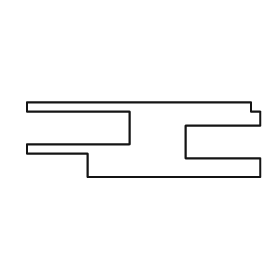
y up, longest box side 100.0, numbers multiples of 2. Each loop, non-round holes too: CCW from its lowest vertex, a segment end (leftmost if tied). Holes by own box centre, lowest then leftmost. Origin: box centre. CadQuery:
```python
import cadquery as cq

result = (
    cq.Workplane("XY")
    .moveTo(-24.0, -16.0)
    .lineTo(50.0, -16.0)
    .lineTo(50.0, -8.0)
    .lineTo(18.0, -8.0)
    .lineTo(18.0, 6.0)
    .lineTo(50.0, 6.0)
    .lineTo(50.0, 12.0)
    .lineTo(46.0, 12.0)
    .lineTo(46.0, 16.0)
    .lineTo(-50.0, 16.0)
    .lineTo(-50.0, 12.0)
    .lineTo(-6.0, 12.0)
    .lineTo(-6.0, -2.0)
    .lineTo(-50.0, -2.0)
    .lineTo(-50.0, -6.0)
    .lineTo(-24.0, -6.0)
    .close()
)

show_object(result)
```